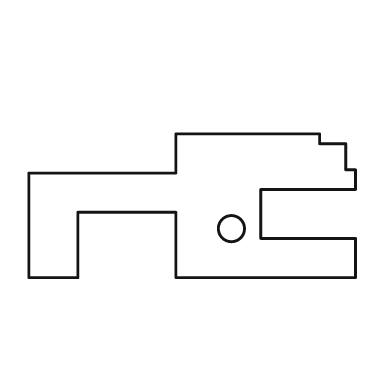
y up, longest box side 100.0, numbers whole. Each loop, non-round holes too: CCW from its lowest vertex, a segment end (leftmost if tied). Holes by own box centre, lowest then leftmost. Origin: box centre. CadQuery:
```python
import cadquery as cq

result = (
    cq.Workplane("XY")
    .moveTo(-50.0, -22.0)
    .lineTo(-35.0, -22.0)
    .lineTo(-35.0, -2.0)
    .lineTo(-5.0, -2.0)
    .lineTo(-5.0, -22.0)
    .lineTo(50.0, -22.0)
    .lineTo(50.0, -10.0)
    .lineTo(21.0, -10.0)
    .lineTo(21.0, 5.0)
    .lineTo(50.0, 5.0)
    .lineTo(50.0, 11.0)
    .lineTo(47.0, 11.0)
    .lineTo(47.0, 19.0)
    .lineTo(39.0, 19.0)
    .lineTo(39.0, 22.0)
    .lineTo(-5.0, 22.0)
    .lineTo(-5.0, 10.0)
    .lineTo(-50.0, 10.0)
    .close()
    .moveTo(12.0, -7.0)
    .circle(4.0)
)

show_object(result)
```